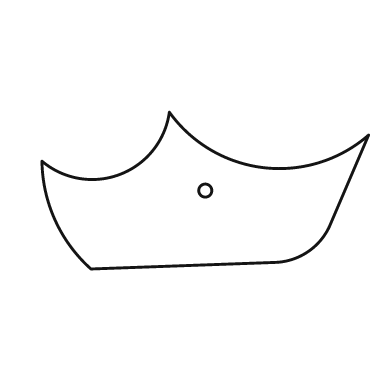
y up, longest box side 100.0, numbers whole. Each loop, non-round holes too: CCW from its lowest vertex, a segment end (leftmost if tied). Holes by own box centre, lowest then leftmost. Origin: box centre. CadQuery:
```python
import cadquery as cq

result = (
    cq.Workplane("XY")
    .moveTo(-35.0, -24.0)
    .lineTo(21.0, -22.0)
    .threePointArc((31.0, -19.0), (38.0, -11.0))
    .lineTo(50.0, 17.0)
    .threePointArc((18.0, 7.0), (-11.0, 24.0))
    .threePointArc((-26.0, 5.0), (-50.0, 9.0))
    .threePointArc((-46.0, -9.0), (-35.0, -24.0))
    .close()
    .moveTo(0.0, 0.0)
    .circle(2.0)
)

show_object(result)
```